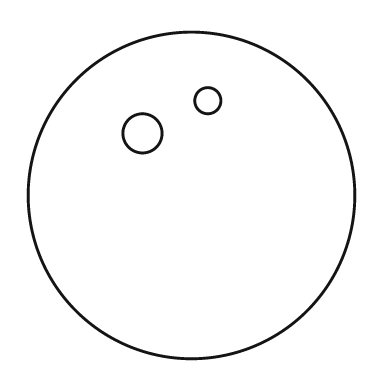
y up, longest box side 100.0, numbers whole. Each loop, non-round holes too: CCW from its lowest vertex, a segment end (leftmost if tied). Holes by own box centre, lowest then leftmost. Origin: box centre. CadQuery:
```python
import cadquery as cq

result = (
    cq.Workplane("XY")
    .moveTo(0.0, 0.0)
    .circle(50.0)
    .moveTo(-15.0, 19.0)
    .circle(6.0)
    .moveTo(5.0, 29.0)
    .circle(4.0)
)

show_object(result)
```